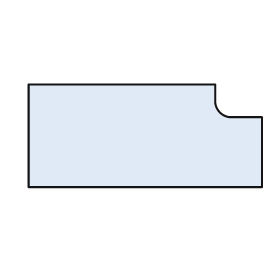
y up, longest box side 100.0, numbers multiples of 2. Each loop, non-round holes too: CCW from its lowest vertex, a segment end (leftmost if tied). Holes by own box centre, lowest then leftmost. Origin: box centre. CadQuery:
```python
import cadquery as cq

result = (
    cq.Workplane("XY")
    .moveTo(-50.0, -22.0)
    .lineTo(50.0, -22.0)
    .lineTo(50.0, 8.0)
    .lineTo(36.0, 8.0)
    .threePointArc((32.0, 10.0), (30.0, 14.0))
    .lineTo(30.0, 22.0)
    .lineTo(-50.0, 22.0)
    .close()
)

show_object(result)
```